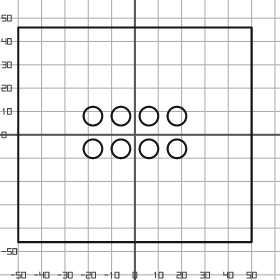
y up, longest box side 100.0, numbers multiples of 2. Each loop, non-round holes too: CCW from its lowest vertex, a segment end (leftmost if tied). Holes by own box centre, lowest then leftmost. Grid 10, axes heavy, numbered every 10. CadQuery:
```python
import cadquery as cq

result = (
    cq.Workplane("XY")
    .moveTo(-50.0, -46.0)
    .lineTo(50.0, -46.0)
    .lineTo(50.0, 46.0)
    .lineTo(-50.0, 46.0)
    .close()
    .moveTo(-18.0, -6.0)
    .circle(4.0)
    .moveTo(-6.0, -6.0)
    .circle(4.0)
    .moveTo(6.0, -6.0)
    .circle(4.0)
    .moveTo(18.0, -6.0)
    .circle(4.0)
    .moveTo(-18.0, 8.0)
    .circle(4.0)
    .moveTo(-6.0, 8.0)
    .circle(4.0)
    .moveTo(6.0, 8.0)
    .circle(4.0)
    .moveTo(18.0, 8.0)
    .circle(4.0)
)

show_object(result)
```